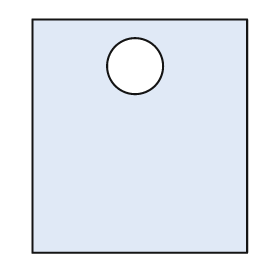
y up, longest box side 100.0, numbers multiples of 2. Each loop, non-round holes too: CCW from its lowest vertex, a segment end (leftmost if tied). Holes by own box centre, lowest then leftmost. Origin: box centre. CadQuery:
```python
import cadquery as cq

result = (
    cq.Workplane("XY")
    .moveTo(-46.0, -50.0)
    .lineTo(46.0, -50.0)
    .lineTo(46.0, 50.0)
    .lineTo(-46.0, 50.0)
    .close()
    .moveTo(-2.0, 30.0)
    .circle(12.0)
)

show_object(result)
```